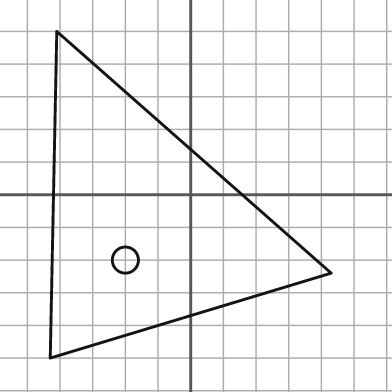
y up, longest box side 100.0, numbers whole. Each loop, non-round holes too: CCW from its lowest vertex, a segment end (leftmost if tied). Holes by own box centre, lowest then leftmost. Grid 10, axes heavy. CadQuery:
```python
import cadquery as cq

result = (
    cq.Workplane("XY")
    .moveTo(-43.0, -50.0)
    .lineTo(43.0, -24.0)
    .lineTo(-41.0, 50.0)
    .close()
    .moveTo(-20.0, -20.0)
    .circle(4.0)
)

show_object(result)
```